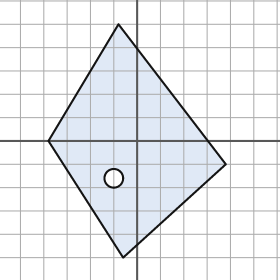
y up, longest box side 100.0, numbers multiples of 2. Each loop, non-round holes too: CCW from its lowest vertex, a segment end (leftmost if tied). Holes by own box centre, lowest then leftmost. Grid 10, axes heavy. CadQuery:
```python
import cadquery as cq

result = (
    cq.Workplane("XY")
    .moveTo(-6.0, -50.0)
    .lineTo(38.0, -10.0)
    .lineTo(-8.0, 50.0)
    .lineTo(-38.0, 0.0)
    .close()
    .moveTo(-10.0, -16.0)
    .circle(4.0)
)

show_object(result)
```